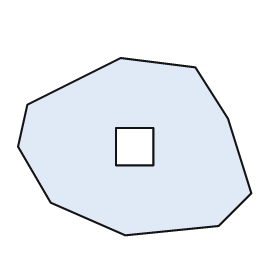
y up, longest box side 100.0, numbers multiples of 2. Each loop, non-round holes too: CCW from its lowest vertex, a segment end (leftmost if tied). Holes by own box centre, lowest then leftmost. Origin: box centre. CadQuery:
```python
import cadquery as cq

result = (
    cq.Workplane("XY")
    .moveTo(-4.0, -38.0)
    .lineTo(36.0, -34.0)
    .lineTo(50.0, -20.0)
    .lineTo(40.0, 12.0)
    .lineTo(26.0, 34.0)
    .lineTo(-6.0, 38.0)
    .lineTo(-46.0, 18.0)
    .lineTo(-50.0, 0.0)
    .lineTo(-36.0, -24.0)
    .close()
    .moveTo(-8.0, -8.0)
    .lineTo(8.0, -8.0)
    .lineTo(8.0, 8.0)
    .lineTo(-8.0, 8.0)
    .close()
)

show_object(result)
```